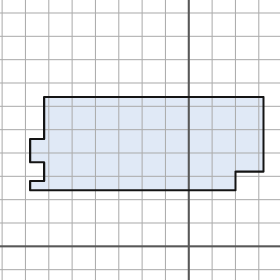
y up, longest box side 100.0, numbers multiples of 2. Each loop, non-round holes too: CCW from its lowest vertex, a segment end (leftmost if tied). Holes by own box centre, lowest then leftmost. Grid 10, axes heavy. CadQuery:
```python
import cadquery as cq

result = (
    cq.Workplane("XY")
    .moveTo(-68.0, 24.0)
    .lineTo(20.0, 24.0)
    .lineTo(20.0, 32.0)
    .lineTo(32.0, 32.0)
    .lineTo(32.0, 64.0)
    .lineTo(-62.0, 64.0)
    .lineTo(-62.0, 46.0)
    .lineTo(-68.0, 46.0)
    .lineTo(-68.0, 36.0)
    .lineTo(-62.0, 36.0)
    .lineTo(-62.0, 28.0)
    .lineTo(-68.0, 28.0)
    .close()
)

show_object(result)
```